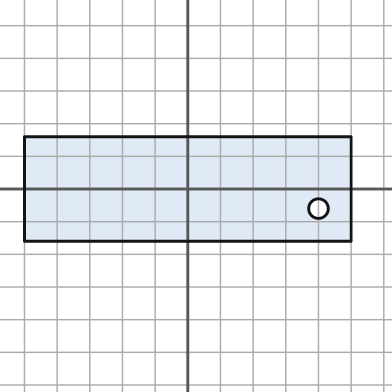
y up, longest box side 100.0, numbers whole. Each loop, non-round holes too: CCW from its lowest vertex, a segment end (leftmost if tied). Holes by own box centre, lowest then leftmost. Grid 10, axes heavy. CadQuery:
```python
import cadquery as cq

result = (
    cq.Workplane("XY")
    .moveTo(-50.0, -16.0)
    .lineTo(50.0, -16.0)
    .lineTo(50.0, 16.0)
    .lineTo(-50.0, 16.0)
    .close()
    .moveTo(40.0, -6.0)
    .circle(3.0)
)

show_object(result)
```